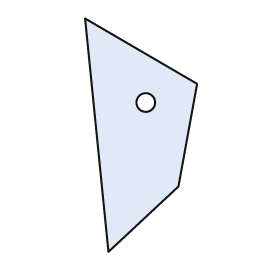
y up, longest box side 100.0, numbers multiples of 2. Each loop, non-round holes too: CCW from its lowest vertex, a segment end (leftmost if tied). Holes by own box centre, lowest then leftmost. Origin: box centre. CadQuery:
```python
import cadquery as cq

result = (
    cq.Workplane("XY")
    .moveTo(-14.0, -50.0)
    .lineTo(16.0, -22.0)
    .lineTo(24.0, 22.0)
    .lineTo(-24.0, 50.0)
    .close()
    .moveTo(2.0, 14.0)
    .circle(4.0)
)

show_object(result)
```